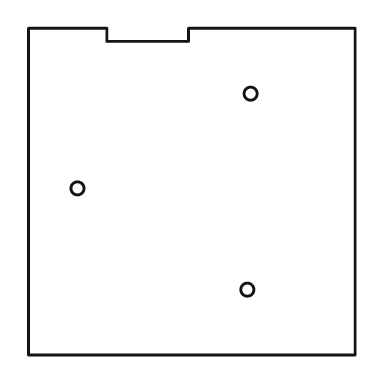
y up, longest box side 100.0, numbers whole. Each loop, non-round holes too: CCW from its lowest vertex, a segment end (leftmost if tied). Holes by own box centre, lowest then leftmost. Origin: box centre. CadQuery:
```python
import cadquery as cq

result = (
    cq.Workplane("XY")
    .moveTo(-50.0, -50.0)
    .lineTo(50.0, -50.0)
    .lineTo(50.0, 50.0)
    .lineTo(-1.0, 50.0)
    .lineTo(-1.0, 46.0)
    .lineTo(-26.0, 46.0)
    .lineTo(-26.0, 50.0)
    .lineTo(-50.0, 50.0)
    .close()
    .moveTo(17.0, -30.0)
    .circle(2.0)
    .moveTo(-35.0, 1.0)
    .circle(2.0)
    .moveTo(18.0, 30.0)
    .circle(2.0)
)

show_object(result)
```